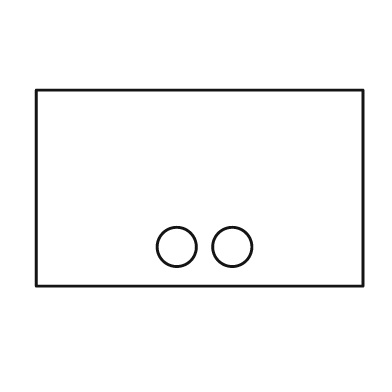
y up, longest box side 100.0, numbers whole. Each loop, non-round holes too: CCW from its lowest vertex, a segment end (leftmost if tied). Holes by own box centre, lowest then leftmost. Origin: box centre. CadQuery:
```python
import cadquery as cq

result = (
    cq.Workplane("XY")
    .moveTo(-50.0, -30.0)
    .lineTo(50.0, -30.0)
    .lineTo(50.0, 30.0)
    .lineTo(-50.0, 30.0)
    .close()
    .moveTo(-7.0, -18.0)
    .circle(6.0)
    .moveTo(10.0, -18.0)
    .circle(6.0)
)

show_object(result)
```